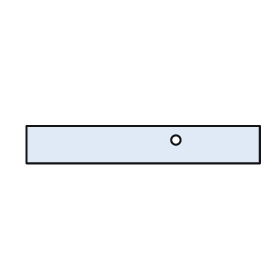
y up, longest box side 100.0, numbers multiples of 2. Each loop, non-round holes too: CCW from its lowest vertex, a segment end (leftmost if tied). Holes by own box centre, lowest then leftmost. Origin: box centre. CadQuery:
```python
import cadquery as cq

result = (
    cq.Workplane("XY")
    .moveTo(-50.0, -8.0)
    .lineTo(50.0, -8.0)
    .lineTo(50.0, 8.0)
    .lineTo(-50.0, 8.0)
    .close()
    .moveTo(14.0, 2.0)
    .circle(2.0)
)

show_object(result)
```